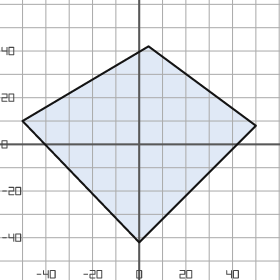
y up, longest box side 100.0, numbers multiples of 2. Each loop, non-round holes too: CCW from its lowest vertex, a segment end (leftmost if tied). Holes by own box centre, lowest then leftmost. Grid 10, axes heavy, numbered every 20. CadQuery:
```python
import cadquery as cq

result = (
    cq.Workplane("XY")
    .moveTo(0.0, -42.0)
    .lineTo(50.0, 8.0)
    .lineTo(4.0, 42.0)
    .lineTo(-50.0, 10.0)
    .close()
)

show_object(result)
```